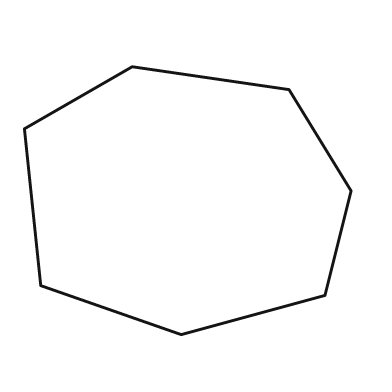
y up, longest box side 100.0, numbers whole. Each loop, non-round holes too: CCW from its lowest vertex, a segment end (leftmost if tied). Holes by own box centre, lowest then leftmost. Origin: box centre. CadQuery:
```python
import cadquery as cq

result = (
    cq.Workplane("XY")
    .moveTo(-2.0, -41.0)
    .lineTo(42.0, -29.0)
    .lineTo(50.0, 3.0)
    .lineTo(31.0, 34.0)
    .lineTo(-17.0, 41.0)
    .lineTo(-50.0, 22.0)
    .lineTo(-45.0, -26.0)
    .close()
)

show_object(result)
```